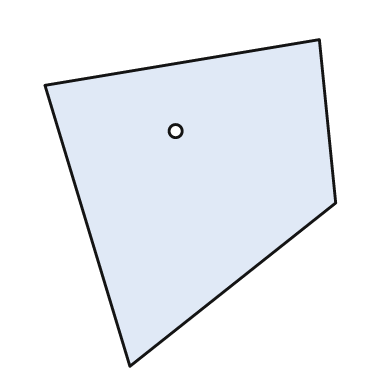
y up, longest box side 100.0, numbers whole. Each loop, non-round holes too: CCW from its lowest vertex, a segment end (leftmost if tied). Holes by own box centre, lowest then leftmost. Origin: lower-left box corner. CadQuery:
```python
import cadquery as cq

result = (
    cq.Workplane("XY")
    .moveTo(26.0, 0.0)
    .lineTo(89.0, 50.0)
    .lineTo(84.0, 100.0)
    .lineTo(0.0, 86.0)
    .close()
    .moveTo(40.0, 72.0)
    .circle(2.0)
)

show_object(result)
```